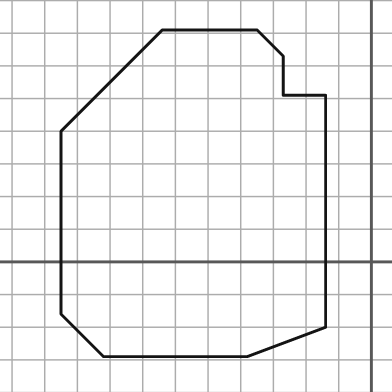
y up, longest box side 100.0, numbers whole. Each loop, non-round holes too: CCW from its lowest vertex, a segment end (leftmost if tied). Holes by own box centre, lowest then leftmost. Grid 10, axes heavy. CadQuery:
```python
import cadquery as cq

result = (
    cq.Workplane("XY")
    .moveTo(-82.0, -29.0)
    .lineTo(-38.0, -29.0)
    .lineTo(-14.0, -20.0)
    .lineTo(-14.0, 51.0)
    .lineTo(-27.0, 51.0)
    .lineTo(-27.0, 63.0)
    .lineTo(-35.0, 71.0)
    .lineTo(-64.0, 71.0)
    .lineTo(-95.0, 40.0)
    .lineTo(-95.0, -16.0)
    .close()
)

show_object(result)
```